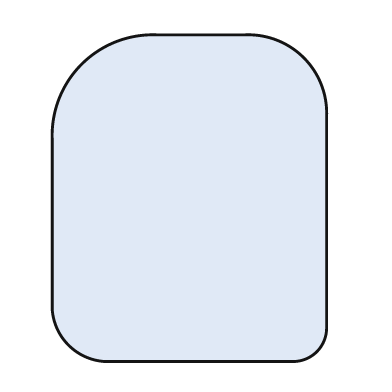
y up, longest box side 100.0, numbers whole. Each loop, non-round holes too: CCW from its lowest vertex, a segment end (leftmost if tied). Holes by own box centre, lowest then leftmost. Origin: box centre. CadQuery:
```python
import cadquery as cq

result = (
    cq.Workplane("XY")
    .moveTo(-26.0, -50.0)
    .lineTo(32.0, -50.0)
    .threePointArc((39.0, -47.0), (42.0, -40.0))
    .lineTo(42.0, 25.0)
    .threePointArc((35.0, 43.0), (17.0, 50.0))
    .lineTo(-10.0, 50.0)
    .threePointArc((-33.0, 41.0), (-42.0, 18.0))
    .lineTo(-42.0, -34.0)
    .threePointArc((-37.0, -45.0), (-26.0, -50.0))
    .close()
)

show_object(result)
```